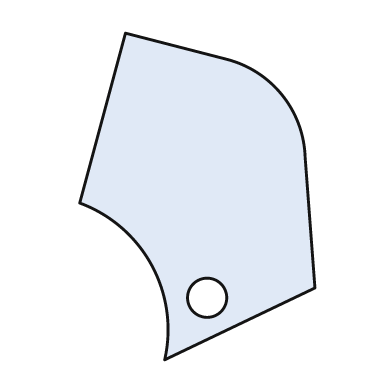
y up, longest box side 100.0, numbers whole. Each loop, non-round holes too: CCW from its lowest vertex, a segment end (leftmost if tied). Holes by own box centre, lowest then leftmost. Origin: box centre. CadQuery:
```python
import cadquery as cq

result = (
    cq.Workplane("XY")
    .moveTo(-10.0, -50.0)
    .lineTo(36.0, -28.0)
    .lineTo(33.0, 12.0)
    .threePointArc((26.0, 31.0), (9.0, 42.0))
    .lineTo(-22.0, 50.0)
    .lineTo(-36.0, -2.0)
    .threePointArc((-14.0, -21.0), (-10.0, -50.0))
    .close()
    .moveTo(3.0, -31.0)
    .circle(6.0)
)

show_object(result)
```